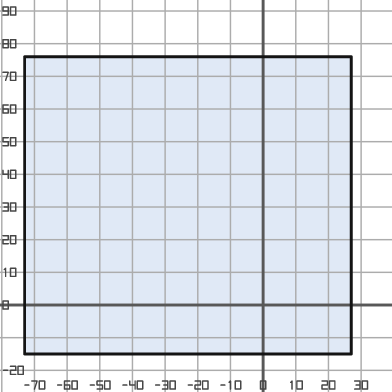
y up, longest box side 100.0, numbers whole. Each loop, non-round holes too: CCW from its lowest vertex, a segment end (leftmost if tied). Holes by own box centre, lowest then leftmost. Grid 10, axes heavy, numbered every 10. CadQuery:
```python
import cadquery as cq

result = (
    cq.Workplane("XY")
    .moveTo(-73.0, -15.0)
    .lineTo(27.0, -15.0)
    .lineTo(27.0, 76.0)
    .lineTo(-73.0, 76.0)
    .close()
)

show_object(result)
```